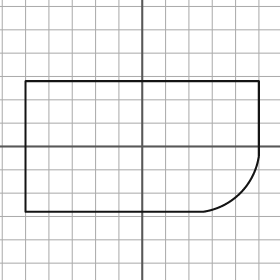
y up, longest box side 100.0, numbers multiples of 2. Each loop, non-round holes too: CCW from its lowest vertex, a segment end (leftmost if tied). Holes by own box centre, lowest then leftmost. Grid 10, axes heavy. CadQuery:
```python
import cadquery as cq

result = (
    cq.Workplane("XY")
    .moveTo(-50.0, -28.0)
    .lineTo(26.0, -28.0)
    .threePointArc((42.0, -20.0), (50.0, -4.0))
    .lineTo(50.0, 28.0)
    .lineTo(-50.0, 28.0)
    .close()
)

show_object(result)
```